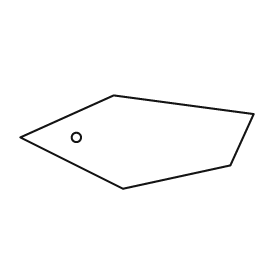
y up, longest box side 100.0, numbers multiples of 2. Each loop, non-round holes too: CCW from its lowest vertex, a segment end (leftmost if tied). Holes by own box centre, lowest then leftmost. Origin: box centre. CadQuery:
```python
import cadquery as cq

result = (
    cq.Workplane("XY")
    .moveTo(-6.0, -20.0)
    .lineTo(40.0, -10.0)
    .lineTo(50.0, 12.0)
    .lineTo(-10.0, 20.0)
    .lineTo(-50.0, 2.0)
    .close()
    .moveTo(-26.0, 2.0)
    .circle(2.0)
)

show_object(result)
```